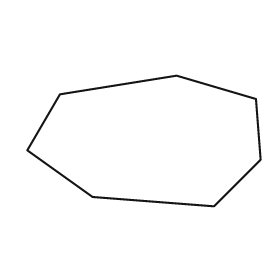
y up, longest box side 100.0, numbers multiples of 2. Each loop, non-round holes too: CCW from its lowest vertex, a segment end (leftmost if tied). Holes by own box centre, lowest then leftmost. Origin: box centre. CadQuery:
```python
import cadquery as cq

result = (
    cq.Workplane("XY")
    .moveTo(30.0, -28.0)
    .lineTo(50.0, -8.0)
    .lineTo(48.0, 18.0)
    .lineTo(14.0, 28.0)
    .lineTo(-36.0, 20.0)
    .lineTo(-50.0, -4.0)
    .lineTo(-22.0, -24.0)
    .close()
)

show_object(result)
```